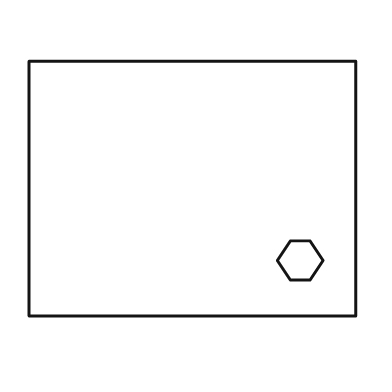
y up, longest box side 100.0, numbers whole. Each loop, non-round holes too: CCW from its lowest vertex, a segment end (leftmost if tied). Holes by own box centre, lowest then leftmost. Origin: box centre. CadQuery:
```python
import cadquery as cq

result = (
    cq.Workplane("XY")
    .moveTo(-50.0, -39.0)
    .lineTo(50.0, -39.0)
    .lineTo(50.0, 39.0)
    .lineTo(-50.0, 39.0)
    .close()
    .moveTo(30.0, -28.0)
    .lineTo(36.0, -28.0)
    .lineTo(40.0, -22.0)
    .lineTo(36.0, -16.0)
    .lineTo(30.0, -16.0)
    .lineTo(26.0, -22.0)
    .close()
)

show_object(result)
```